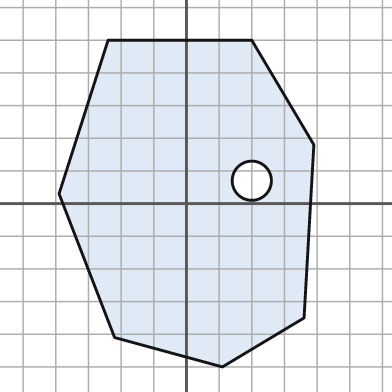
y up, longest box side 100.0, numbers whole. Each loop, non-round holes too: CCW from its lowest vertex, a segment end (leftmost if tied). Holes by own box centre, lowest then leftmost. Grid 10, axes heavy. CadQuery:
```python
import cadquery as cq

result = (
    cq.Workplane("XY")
    .moveTo(11.0, -50.0)
    .lineTo(36.0, -35.0)
    .lineTo(39.0, 18.0)
    .lineTo(20.0, 50.0)
    .lineTo(-24.0, 50.0)
    .lineTo(-39.0, 3.0)
    .lineTo(-22.0, -41.0)
    .close()
    .moveTo(20.0, 7.0)
    .circle(6.0)
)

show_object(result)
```